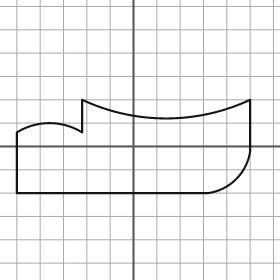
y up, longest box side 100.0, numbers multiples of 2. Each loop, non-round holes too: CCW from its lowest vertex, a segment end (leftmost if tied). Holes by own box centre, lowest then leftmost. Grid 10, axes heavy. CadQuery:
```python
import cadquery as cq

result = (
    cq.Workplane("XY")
    .moveTo(-50.0, -20.0)
    .lineTo(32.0, -20.0)
    .threePointArc((44.0, -14.0), (50.0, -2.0))
    .lineTo(50.0, 20.0)
    .threePointArc((14.0, 12.0), (-22.0, 20.0))
    .lineTo(-22.0, 6.0)
    .threePointArc((-36.0, 10.0), (-50.0, 6.0))
    .close()
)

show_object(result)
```